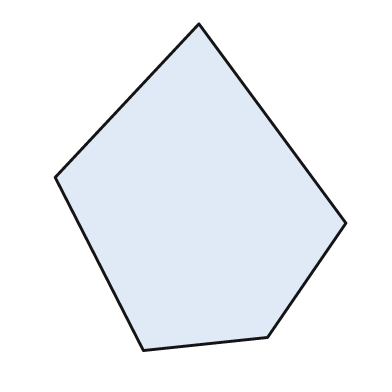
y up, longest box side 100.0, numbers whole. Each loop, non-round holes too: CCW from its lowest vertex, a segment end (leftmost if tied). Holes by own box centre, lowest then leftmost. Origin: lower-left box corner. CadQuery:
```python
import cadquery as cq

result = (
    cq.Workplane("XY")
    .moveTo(27.0, 0.0)
    .lineTo(65.0, 4.0)
    .lineTo(89.0, 39.0)
    .lineTo(44.0, 100.0)
    .lineTo(0.0, 53.0)
    .close()
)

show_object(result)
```